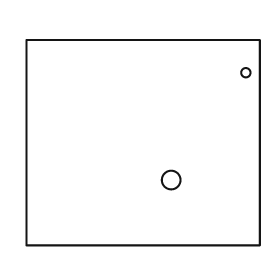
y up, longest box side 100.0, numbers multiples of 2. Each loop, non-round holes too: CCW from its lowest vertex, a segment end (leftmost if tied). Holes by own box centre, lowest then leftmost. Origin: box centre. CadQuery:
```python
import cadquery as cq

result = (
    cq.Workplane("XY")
    .moveTo(-50.0, -44.0)
    .lineTo(50.0, -44.0)
    .lineTo(50.0, 44.0)
    .lineTo(-50.0, 44.0)
    .close()
    .moveTo(12.0, -16.0)
    .circle(4.0)
    .moveTo(44.0, 30.0)
    .circle(2.0)
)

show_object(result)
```